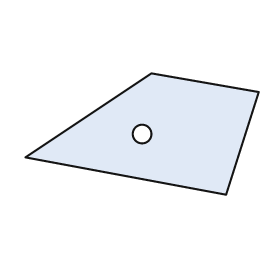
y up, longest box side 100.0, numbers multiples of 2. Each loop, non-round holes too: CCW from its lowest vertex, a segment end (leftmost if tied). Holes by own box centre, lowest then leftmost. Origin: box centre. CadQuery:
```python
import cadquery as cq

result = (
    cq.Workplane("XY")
    .moveTo(36.0, -26.0)
    .lineTo(50.0, 18.0)
    .lineTo(4.0, 26.0)
    .lineTo(-50.0, -10.0)
    .close()
    .moveTo(0.0, 0.0)
    .circle(4.0)
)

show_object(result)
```